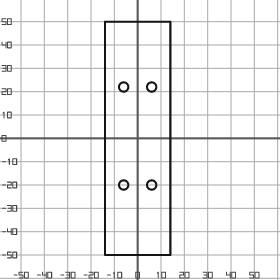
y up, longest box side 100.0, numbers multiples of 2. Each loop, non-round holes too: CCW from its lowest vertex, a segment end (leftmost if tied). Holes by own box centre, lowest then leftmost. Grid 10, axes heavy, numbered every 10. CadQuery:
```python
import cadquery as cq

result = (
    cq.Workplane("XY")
    .moveTo(-14.0, -50.0)
    .lineTo(14.0, -50.0)
    .lineTo(14.0, 50.0)
    .lineTo(-14.0, 50.0)
    .close()
    .moveTo(-6.0, -20.0)
    .circle(2.0)
    .moveTo(6.0, -20.0)
    .circle(2.0)
    .moveTo(-6.0, 22.0)
    .circle(2.0)
    .moveTo(6.0, 22.0)
    .circle(2.0)
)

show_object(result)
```